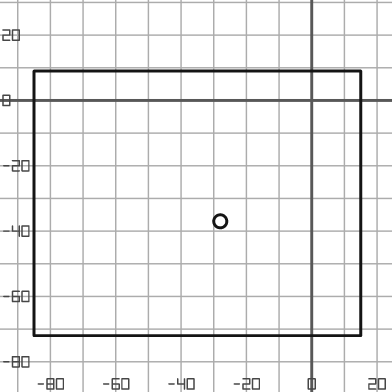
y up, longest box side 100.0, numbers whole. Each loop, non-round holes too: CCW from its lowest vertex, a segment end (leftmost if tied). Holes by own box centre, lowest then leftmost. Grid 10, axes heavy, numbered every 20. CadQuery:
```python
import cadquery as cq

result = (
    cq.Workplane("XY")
    .moveTo(-85.0, -72.0)
    .lineTo(15.0, -72.0)
    .lineTo(15.0, 9.0)
    .lineTo(-85.0, 9.0)
    .close()
    .moveTo(-28.0, -37.0)
    .circle(2.0)
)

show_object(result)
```